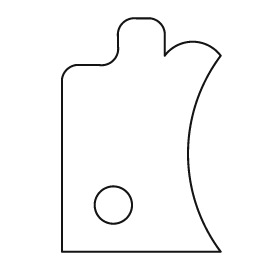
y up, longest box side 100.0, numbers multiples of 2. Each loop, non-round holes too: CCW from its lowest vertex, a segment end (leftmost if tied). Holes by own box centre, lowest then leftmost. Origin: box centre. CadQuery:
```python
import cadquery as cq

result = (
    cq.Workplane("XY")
    .moveTo(-34.0, -50.0)
    .lineTo(34.0, -50.0)
    .threePointArc((20.0, -8.0), (34.0, 34.0))
    .threePointArc((22.0, 40.0), (10.0, 34.0))
    .lineTo(10.0, 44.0)
    .threePointArc((8.0, 48.0), (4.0, 50.0))
    .lineTo(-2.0, 50.0)
    .threePointArc((-8.0, 48.0), (-10.0, 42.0))
    .lineTo(-10.0, 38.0)
    .threePointArc((-12.0, 32.0), (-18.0, 30.0))
    .lineTo(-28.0, 30.0)
    .threePointArc((-32.0, 28.0), (-34.0, 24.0))
    .close()
    .moveTo(-12.0, -30.0)
    .circle(8.0)
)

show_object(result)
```